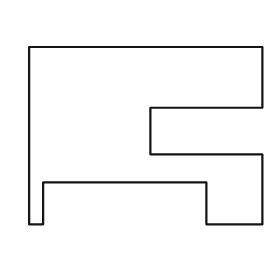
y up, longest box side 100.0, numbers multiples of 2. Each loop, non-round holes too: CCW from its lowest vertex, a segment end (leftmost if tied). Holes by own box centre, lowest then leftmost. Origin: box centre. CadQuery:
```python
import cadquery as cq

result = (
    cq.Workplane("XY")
    .moveTo(-50.0, -38.0)
    .lineTo(-44.0, -38.0)
    .lineTo(-44.0, -20.0)
    .lineTo(26.0, -20.0)
    .lineTo(26.0, -38.0)
    .lineTo(50.0, -38.0)
    .lineTo(50.0, -8.0)
    .lineTo(2.0, -8.0)
    .lineTo(2.0, 12.0)
    .lineTo(50.0, 12.0)
    .lineTo(50.0, 38.0)
    .lineTo(-50.0, 38.0)
    .close()
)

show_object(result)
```